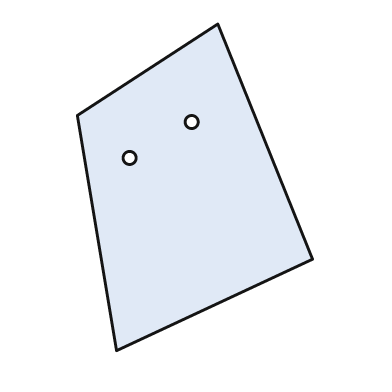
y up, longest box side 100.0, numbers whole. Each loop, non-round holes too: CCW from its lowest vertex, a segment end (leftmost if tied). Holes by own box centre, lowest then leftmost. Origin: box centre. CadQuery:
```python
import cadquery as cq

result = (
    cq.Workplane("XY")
    .moveTo(-24.0, -50.0)
    .lineTo(36.0, -22.0)
    .lineTo(7.0, 50.0)
    .lineTo(-36.0, 22.0)
    .close()
    .moveTo(-20.0, 9.0)
    .circle(2.0)
    .moveTo(-1.0, 20.0)
    .circle(2.0)
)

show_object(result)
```